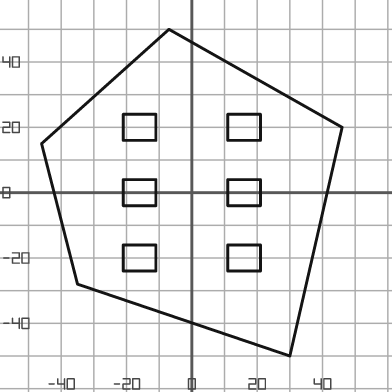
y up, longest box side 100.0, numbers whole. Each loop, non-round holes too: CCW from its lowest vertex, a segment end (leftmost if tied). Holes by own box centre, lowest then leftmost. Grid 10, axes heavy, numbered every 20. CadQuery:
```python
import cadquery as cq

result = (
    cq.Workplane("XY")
    .moveTo(30.0, -50.0)
    .lineTo(46.0, 20.0)
    .lineTo(-7.0, 50.0)
    .lineTo(-46.0, 15.0)
    .lineTo(-35.0, -28.0)
    .close()
    .moveTo(-21.0, -24.0)
    .lineTo(-11.0, -24.0)
    .lineTo(-11.0, -16.0)
    .lineTo(-21.0, -16.0)
    .close()
    .moveTo(11.0, -24.0)
    .lineTo(21.0, -24.0)
    .lineTo(21.0, -16.0)
    .lineTo(11.0, -16.0)
    .close()
    .moveTo(-21.0, -4.0)
    .lineTo(-11.0, -4.0)
    .lineTo(-11.0, 4.0)
    .lineTo(-21.0, 4.0)
    .close()
    .moveTo(11.0, -4.0)
    .lineTo(21.0, -4.0)
    .lineTo(21.0, 4.0)
    .lineTo(11.0, 4.0)
    .close()
    .moveTo(-21.0, 16.0)
    .lineTo(-11.0, 16.0)
    .lineTo(-11.0, 24.0)
    .lineTo(-21.0, 24.0)
    .close()
    .moveTo(11.0, 16.0)
    .lineTo(21.0, 16.0)
    .lineTo(21.0, 24.0)
    .lineTo(11.0, 24.0)
    .close()
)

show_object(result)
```